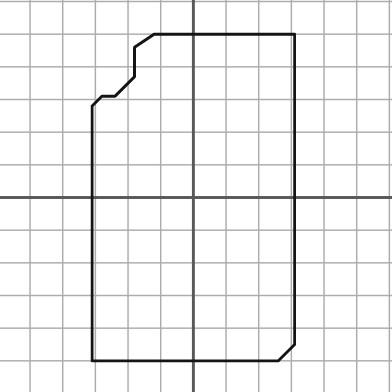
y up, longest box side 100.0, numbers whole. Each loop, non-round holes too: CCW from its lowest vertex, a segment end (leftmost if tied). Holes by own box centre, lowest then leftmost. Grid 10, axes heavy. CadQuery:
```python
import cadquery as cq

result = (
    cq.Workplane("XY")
    .moveTo(-31.0, -50.0)
    .lineTo(26.0, -50.0)
    .lineTo(31.0, -45.0)
    .lineTo(31.0, 50.0)
    .lineTo(-12.0, 50.0)
    .lineTo(-18.0, 46.0)
    .lineTo(-18.0, 37.0)
    .lineTo(-24.0, 31.0)
    .lineTo(-28.0, 31.0)
    .lineTo(-31.0, 28.0)
    .close()
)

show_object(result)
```